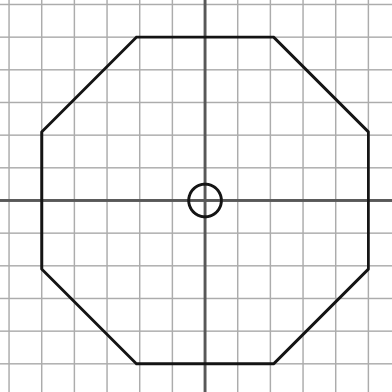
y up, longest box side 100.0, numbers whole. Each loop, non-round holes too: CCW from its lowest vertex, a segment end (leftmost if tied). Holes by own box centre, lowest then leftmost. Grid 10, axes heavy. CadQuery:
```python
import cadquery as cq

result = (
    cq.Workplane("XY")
    .moveTo(-21.0, -50.0)
    .lineTo(21.0, -50.0)
    .lineTo(50.0, -21.0)
    .lineTo(50.0, 21.0)
    .lineTo(21.0, 50.0)
    .lineTo(-21.0, 50.0)
    .lineTo(-50.0, 21.0)
    .lineTo(-50.0, -21.0)
    .close()
    .moveTo(0.0, 0.0)
    .circle(5.0)
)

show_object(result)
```